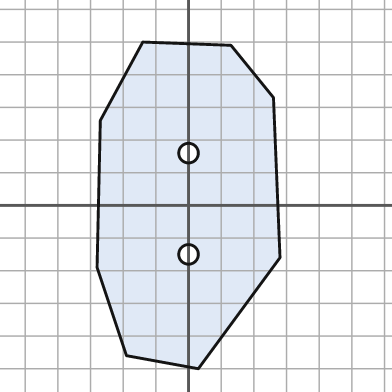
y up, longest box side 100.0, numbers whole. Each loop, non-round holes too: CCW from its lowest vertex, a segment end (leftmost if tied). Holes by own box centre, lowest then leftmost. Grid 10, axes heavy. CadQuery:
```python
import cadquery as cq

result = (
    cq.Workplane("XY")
    .moveTo(3.0, -50.0)
    .lineTo(28.0, -16.0)
    .lineTo(26.0, 33.0)
    .lineTo(13.0, 49.0)
    .lineTo(-14.0, 50.0)
    .lineTo(-27.0, 26.0)
    .lineTo(-28.0, -19.0)
    .lineTo(-19.0, -46.0)
    .close()
    .moveTo(0.0, -15.0)
    .circle(3.0)
    .moveTo(0.0, 16.0)
    .circle(3.0)
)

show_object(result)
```